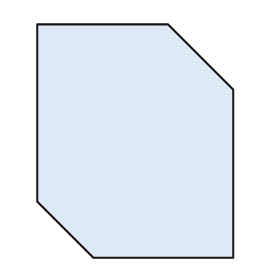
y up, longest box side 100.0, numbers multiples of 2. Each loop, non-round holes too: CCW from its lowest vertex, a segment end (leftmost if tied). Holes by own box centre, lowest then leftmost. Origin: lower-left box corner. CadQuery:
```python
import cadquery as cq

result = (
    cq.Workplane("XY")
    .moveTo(24.0, 0.0)
    .lineTo(84.0, 0.0)
    .lineTo(84.0, 72.0)
    .lineTo(56.0, 100.0)
    .lineTo(0.0, 100.0)
    .lineTo(0.0, 24.0)
    .close()
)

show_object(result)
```